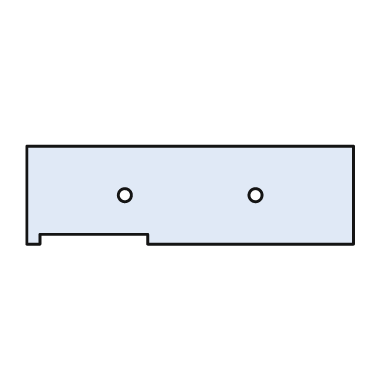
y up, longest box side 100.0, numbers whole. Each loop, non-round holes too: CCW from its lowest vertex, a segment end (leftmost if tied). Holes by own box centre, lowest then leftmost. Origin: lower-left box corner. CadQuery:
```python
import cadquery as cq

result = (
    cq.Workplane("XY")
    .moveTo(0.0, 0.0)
    .lineTo(4.0, 0.0)
    .lineTo(4.0, 3.0)
    .lineTo(37.0, 3.0)
    .lineTo(37.0, 0.0)
    .lineTo(100.0, 0.0)
    .lineTo(100.0, 30.0)
    .lineTo(0.0, 30.0)
    .close()
    .moveTo(30.0, 15.0)
    .circle(2.0)
    .moveTo(70.0, 15.0)
    .circle(2.0)
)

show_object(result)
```